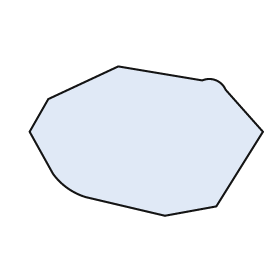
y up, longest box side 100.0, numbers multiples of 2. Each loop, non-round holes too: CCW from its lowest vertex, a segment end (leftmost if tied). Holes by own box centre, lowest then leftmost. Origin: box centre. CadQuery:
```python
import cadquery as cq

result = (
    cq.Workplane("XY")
    .moveTo(8.0, -32.0)
    .lineTo(30.0, -28.0)
    .lineTo(50.0, 4.0)
    .lineTo(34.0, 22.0)
    .threePointArc((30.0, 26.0), (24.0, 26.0))
    .lineTo(-12.0, 32.0)
    .lineTo(-42.0, 18.0)
    .lineTo(-50.0, 4.0)
    .lineTo(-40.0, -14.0)
    .threePointArc((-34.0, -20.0), (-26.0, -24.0))
    .close()
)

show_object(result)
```